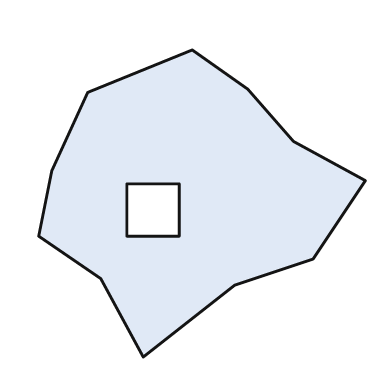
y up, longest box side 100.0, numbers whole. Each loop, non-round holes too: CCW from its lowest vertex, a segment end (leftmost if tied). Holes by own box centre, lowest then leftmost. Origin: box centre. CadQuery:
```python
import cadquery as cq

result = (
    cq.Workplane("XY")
    .moveTo(-18.0, -47.0)
    .lineTo(10.0, -25.0)
    .lineTo(34.0, -17.0)
    .lineTo(50.0, 7.0)
    .lineTo(28.0, 19.0)
    .lineTo(14.0, 35.0)
    .lineTo(-3.0, 47.0)
    .lineTo(-35.0, 34.0)
    .lineTo(-46.0, 10.0)
    .lineTo(-50.0, -10.0)
    .lineTo(-31.0, -23.0)
    .close()
    .moveTo(-23.0, -10.0)
    .lineTo(-7.0, -10.0)
    .lineTo(-7.0, 6.0)
    .lineTo(-23.0, 6.0)
    .close()
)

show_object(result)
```